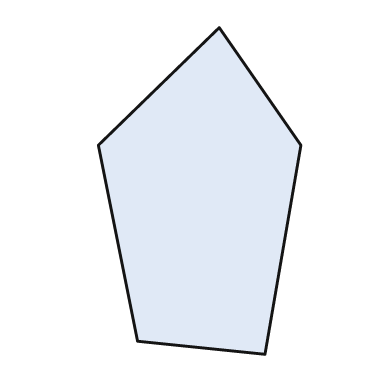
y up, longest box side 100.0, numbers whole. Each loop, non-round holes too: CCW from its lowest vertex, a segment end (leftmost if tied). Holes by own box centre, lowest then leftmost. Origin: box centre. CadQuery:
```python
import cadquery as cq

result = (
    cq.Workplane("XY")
    .moveTo(20.0, -50.0)
    .lineTo(31.0, 14.0)
    .lineTo(6.0, 50.0)
    .lineTo(-31.0, 14.0)
    .lineTo(-19.0, -46.0)
    .close()
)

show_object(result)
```